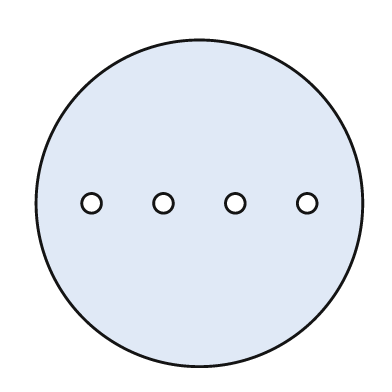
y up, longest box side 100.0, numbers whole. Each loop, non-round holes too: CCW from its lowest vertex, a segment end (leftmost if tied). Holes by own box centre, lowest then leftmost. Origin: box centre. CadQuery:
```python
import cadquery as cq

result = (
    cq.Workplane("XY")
    .moveTo(0.0, 0.0)
    .circle(50.0)
    .moveTo(-33.0, 0.0)
    .circle(3.0)
    .moveTo(-11.0, 0.0)
    .circle(3.0)
    .moveTo(11.0, 0.0)
    .circle(3.0)
    .moveTo(33.0, 0.0)
    .circle(3.0)
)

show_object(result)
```